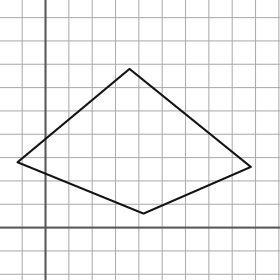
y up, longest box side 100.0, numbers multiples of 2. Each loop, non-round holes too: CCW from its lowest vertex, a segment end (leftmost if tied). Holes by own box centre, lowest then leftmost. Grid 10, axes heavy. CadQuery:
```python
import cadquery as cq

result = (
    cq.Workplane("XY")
    .moveTo(42.0, 6.0)
    .lineTo(88.0, 26.0)
    .lineTo(36.0, 68.0)
    .lineTo(-12.0, 28.0)
    .close()
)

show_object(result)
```